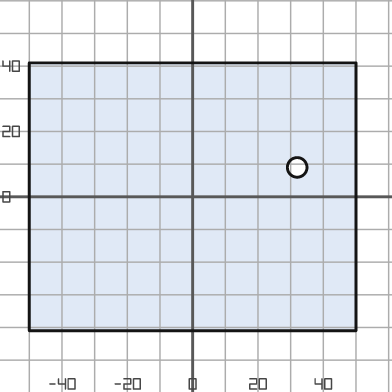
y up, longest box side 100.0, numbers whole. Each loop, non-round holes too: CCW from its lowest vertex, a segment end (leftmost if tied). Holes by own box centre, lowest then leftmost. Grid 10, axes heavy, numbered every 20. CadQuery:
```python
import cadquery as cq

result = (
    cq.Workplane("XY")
    .moveTo(-50.0, -41.0)
    .lineTo(50.0, -41.0)
    .lineTo(50.0, 41.0)
    .lineTo(-50.0, 41.0)
    .close()
    .moveTo(32.0, 9.0)
    .circle(3.0)
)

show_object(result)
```